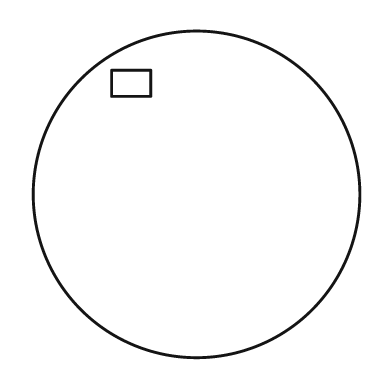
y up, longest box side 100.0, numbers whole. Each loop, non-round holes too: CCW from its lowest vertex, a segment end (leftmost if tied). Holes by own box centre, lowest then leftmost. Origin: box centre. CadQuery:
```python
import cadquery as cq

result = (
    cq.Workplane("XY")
    .moveTo(0.0, 0.0)
    .circle(50.0)
    .moveTo(-26.0, 30.0)
    .lineTo(-14.0, 30.0)
    .lineTo(-14.0, 38.0)
    .lineTo(-26.0, 38.0)
    .close()
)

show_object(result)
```